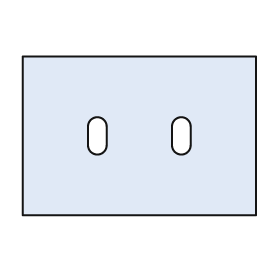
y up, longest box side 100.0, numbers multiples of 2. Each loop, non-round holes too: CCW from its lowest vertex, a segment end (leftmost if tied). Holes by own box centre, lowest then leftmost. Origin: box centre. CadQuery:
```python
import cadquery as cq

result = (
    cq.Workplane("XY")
    .moveTo(-50.0, -34.0)
    .lineTo(50.0, -34.0)
    .lineTo(50.0, 34.0)
    .lineTo(-50.0, 34.0)
    .close()
    .moveTo(-22.0, -4.0)
    .threePointArc((-18.0, -8.0), (-14.0, -4.0))
    .lineTo(-14.0, 4.0)
    .threePointArc((-18.0, 8.0), (-22.0, 4.0))
    .close()
    .moveTo(14.0, -4.0)
    .threePointArc((18.0, -8.0), (22.0, -4.0))
    .lineTo(22.0, 4.0)
    .threePointArc((18.0, 8.0), (14.0, 4.0))
    .close()
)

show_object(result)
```